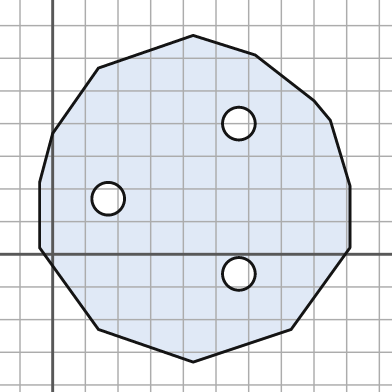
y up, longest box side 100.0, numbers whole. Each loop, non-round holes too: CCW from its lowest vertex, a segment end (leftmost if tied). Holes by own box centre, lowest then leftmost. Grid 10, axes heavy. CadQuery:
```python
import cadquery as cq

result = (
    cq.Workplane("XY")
    .moveTo(43.0, -33.0)
    .lineTo(73.0, -23.0)
    .lineTo(91.0, 2.0)
    .lineTo(91.0, 21.0)
    .lineTo(85.0, 41.0)
    .lineTo(80.0, 47.0)
    .lineTo(62.0, 61.0)
    .lineTo(43.0, 67.0)
    .lineTo(14.0, 57.0)
    .lineTo(0.0, 37.0)
    .lineTo(-4.0, 22.0)
    .lineTo(-4.0, 2.0)
    .lineTo(14.0, -23.0)
    .close()
    .moveTo(57.0, -6.0)
    .circle(5.0)
    .moveTo(17.0, 17.0)
    .circle(5.0)
    .moveTo(57.0, 40.0)
    .circle(5.0)
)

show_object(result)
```